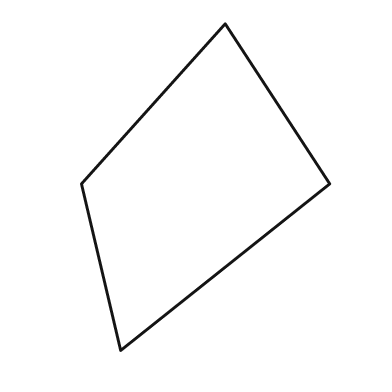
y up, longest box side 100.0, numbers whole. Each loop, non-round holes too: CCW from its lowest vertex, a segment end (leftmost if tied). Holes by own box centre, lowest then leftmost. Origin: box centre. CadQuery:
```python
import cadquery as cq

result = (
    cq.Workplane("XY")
    .moveTo(-26.0, -50.0)
    .lineTo(38.0, 1.0)
    .lineTo(6.0, 50.0)
    .lineTo(-38.0, 1.0)
    .close()
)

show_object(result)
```